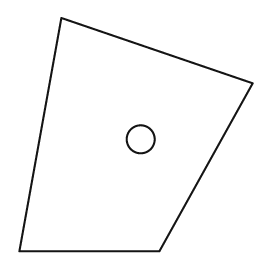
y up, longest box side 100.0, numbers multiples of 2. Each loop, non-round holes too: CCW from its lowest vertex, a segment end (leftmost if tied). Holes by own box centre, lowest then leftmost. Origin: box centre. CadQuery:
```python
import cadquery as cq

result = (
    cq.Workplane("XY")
    .moveTo(-50.0, -50.0)
    .lineTo(10.0, -50.0)
    .lineTo(50.0, 22.0)
    .lineTo(-32.0, 50.0)
    .close()
    .moveTo(2.0, -2.0)
    .circle(6.0)
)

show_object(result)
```